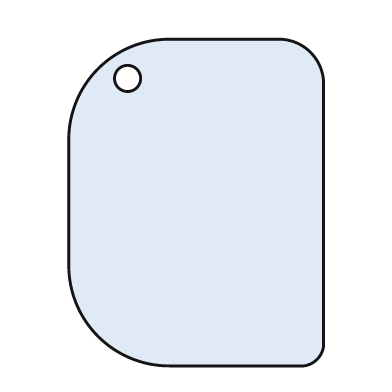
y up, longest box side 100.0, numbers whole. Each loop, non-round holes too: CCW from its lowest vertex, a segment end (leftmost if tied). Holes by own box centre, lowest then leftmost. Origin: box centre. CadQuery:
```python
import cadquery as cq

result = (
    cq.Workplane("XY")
    .moveTo(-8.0, -50.0)
    .lineTo(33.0, -50.0)
    .threePointArc((37.0, -48.0), (39.0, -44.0))
    .lineTo(39.0, 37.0)
    .threePointArc((35.0, 46.0), (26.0, 50.0))
    .lineTo(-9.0, 50.0)
    .threePointArc((-30.0, 41.0), (-39.0, 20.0))
    .lineTo(-39.0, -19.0)
    .threePointArc((-30.0, -41.0), (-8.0, -50.0))
    .close()
    .moveTo(-21.0, 38.0)
    .circle(4.0)
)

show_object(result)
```